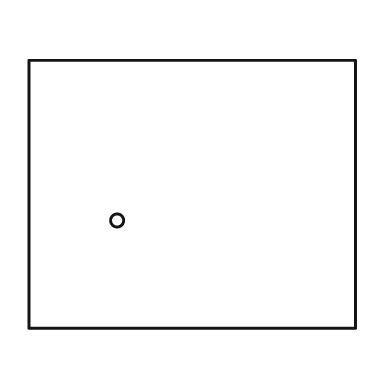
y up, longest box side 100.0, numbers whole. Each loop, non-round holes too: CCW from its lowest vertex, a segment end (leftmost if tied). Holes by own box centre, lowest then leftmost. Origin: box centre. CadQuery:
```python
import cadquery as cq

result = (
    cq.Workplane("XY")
    .moveTo(-50.0, -41.0)
    .lineTo(50.0, -41.0)
    .lineTo(50.0, 41.0)
    .lineTo(-50.0, 41.0)
    .close()
    .moveTo(-23.0, -8.0)
    .circle(2.0)
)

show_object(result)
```